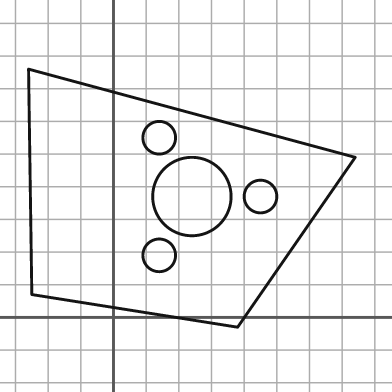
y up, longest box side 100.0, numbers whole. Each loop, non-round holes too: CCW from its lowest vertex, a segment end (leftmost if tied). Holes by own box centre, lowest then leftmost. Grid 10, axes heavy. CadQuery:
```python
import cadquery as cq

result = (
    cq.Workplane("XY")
    .moveTo(38.0, -3.0)
    .lineTo(74.0, 49.0)
    .lineTo(-26.0, 76.0)
    .lineTo(-25.0, 7.0)
    .close()
    .moveTo(14.0, 19.0)
    .circle(5.0)
    .moveTo(24.0, 37.0)
    .circle(12.0)
    .moveTo(45.0, 37.0)
    .circle(5.0)
    .moveTo(14.0, 55.0)
    .circle(5.0)
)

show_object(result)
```